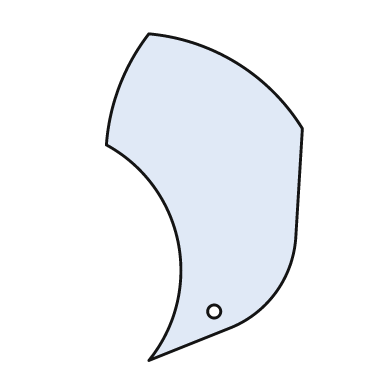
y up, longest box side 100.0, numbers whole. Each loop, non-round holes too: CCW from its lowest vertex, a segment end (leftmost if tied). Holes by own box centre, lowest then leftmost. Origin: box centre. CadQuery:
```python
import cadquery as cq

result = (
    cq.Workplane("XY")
    .moveTo(-17.0, -50.0)
    .lineTo(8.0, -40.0)
    .threePointArc((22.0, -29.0), (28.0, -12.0))
    .lineTo(30.0, 21.0)
    .threePointArc((10.0, 41.0), (-17.0, 50.0))
    .threePointArc((-26.0, 34.0), (-30.0, 16.0))
    .threePointArc((-8.0, -14.0), (-17.0, -50.0))
    .close()
    .moveTo(3.0, -35.0)
    .circle(2.0)
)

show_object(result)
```